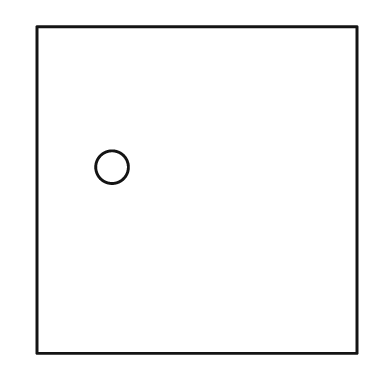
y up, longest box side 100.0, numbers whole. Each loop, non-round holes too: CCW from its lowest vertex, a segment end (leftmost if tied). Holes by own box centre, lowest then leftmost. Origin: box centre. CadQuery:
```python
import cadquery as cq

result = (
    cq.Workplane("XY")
    .moveTo(-49.0, -50.0)
    .lineTo(49.0, -50.0)
    .lineTo(49.0, 50.0)
    .lineTo(-49.0, 50.0)
    .close()
    .moveTo(-26.0, 7.0)
    .circle(5.0)
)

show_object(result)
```